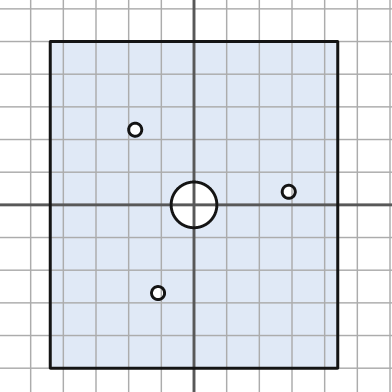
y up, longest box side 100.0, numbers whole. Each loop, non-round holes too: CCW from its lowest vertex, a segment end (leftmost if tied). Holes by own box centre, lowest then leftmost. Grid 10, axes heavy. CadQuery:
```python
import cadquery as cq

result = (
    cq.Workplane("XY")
    .moveTo(-44.0, -50.0)
    .lineTo(44.0, -50.0)
    .lineTo(44.0, 50.0)
    .lineTo(-44.0, 50.0)
    .close()
    .moveTo(-11.0, -27.0)
    .circle(2.0)
    .moveTo(0.0, 0.0)
    .circle(7.0)
    .moveTo(29.0, 4.0)
    .circle(2.0)
    .moveTo(-18.0, 23.0)
    .circle(2.0)
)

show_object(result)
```